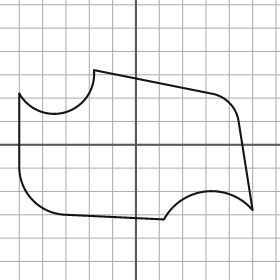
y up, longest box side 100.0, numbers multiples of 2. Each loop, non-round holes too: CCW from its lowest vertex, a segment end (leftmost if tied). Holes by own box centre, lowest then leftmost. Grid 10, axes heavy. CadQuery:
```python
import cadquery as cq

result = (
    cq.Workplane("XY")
    .moveTo(12.0, -32.0)
    .threePointArc((30.0, -20.0), (50.0, -28.0))
    .lineTo(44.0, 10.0)
    .threePointArc((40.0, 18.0), (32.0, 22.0))
    .lineTo(-18.0, 32.0)
    .threePointArc((-30.0, 14.0), (-50.0, 22.0))
    .lineTo(-50.0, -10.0)
    .threePointArc((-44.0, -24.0), (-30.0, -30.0))
    .close()
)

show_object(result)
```